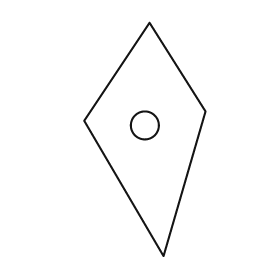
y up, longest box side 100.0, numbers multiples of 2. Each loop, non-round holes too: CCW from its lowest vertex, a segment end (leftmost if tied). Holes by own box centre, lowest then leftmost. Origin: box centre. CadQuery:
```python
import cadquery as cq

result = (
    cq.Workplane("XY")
    .moveTo(8.0, -50.0)
    .lineTo(26.0, 12.0)
    .lineTo(2.0, 50.0)
    .lineTo(-26.0, 8.0)
    .close()
    .moveTo(0.0, 6.0)
    .circle(6.0)
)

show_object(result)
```